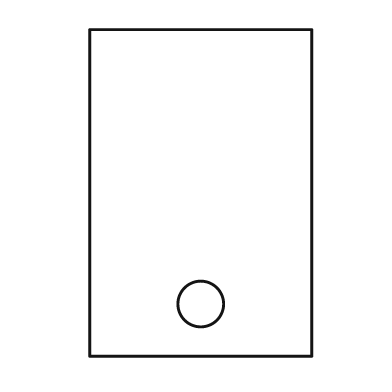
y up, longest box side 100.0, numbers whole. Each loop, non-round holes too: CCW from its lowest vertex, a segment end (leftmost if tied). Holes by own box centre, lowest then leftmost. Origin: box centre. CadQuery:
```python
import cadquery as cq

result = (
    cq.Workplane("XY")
    .moveTo(-34.0, -50.0)
    .lineTo(34.0, -50.0)
    .lineTo(34.0, 50.0)
    .lineTo(-34.0, 50.0)
    .close()
    .moveTo(0.0, -34.0)
    .circle(7.0)
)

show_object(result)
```